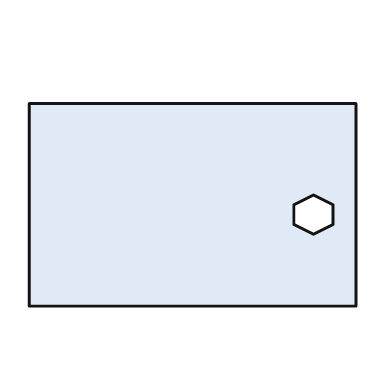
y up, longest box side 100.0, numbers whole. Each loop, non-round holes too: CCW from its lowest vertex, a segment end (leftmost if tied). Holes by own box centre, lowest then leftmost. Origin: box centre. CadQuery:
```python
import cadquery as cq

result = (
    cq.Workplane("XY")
    .moveTo(-50.0, -31.0)
    .lineTo(50.0, -31.0)
    .lineTo(50.0, 31.0)
    .lineTo(-50.0, 31.0)
    .close()
    .moveTo(37.0, -9.0)
    .lineTo(43.0, -6.0)
    .lineTo(43.0, 0.0)
    .lineTo(37.0, 3.0)
    .lineTo(31.0, 0.0)
    .lineTo(31.0, -6.0)
    .close()
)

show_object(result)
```